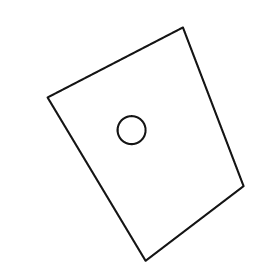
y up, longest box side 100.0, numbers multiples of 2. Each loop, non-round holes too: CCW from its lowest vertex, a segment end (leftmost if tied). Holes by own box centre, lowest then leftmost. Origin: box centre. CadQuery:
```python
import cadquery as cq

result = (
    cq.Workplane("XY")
    .moveTo(0.0, -50.0)
    .lineTo(42.0, -18.0)
    .lineTo(16.0, 50.0)
    .lineTo(-42.0, 20.0)
    .close()
    .moveTo(-6.0, 6.0)
    .circle(6.0)
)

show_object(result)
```